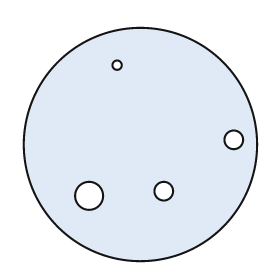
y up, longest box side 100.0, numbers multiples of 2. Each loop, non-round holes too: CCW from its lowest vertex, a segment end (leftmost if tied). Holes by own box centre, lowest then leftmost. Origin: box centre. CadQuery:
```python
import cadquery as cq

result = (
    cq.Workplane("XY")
    .moveTo(0.0, 0.0)
    .circle(50.0)
    .moveTo(-22.0, -22.0)
    .circle(6.0)
    .moveTo(10.0, -20.0)
    .circle(4.0)
    .moveTo(40.0, 2.0)
    .circle(4.0)
    .moveTo(-10.0, 34.0)
    .circle(2.0)
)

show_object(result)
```